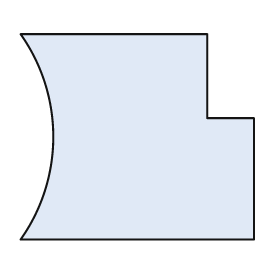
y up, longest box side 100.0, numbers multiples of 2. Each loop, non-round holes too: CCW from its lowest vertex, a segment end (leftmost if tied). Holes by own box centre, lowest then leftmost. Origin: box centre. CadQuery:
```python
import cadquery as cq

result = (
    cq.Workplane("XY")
    .moveTo(-50.0, -44.0)
    .lineTo(50.0, -44.0)
    .lineTo(50.0, 8.0)
    .lineTo(30.0, 8.0)
    .lineTo(30.0, 44.0)
    .lineTo(-50.0, 44.0)
    .threePointArc((-36.0, 0.0), (-50.0, -44.0))
    .close()
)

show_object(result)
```